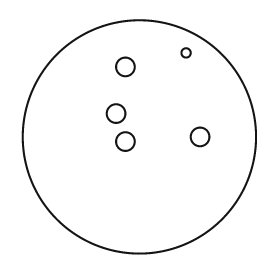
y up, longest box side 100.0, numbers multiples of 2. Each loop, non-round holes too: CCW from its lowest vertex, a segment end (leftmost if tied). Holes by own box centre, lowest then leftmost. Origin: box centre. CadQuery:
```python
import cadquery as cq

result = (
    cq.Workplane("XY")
    .moveTo(0.0, 0.0)
    .circle(50.0)
    .moveTo(-6.0, -2.0)
    .circle(4.0)
    .moveTo(26.0, 0.0)
    .circle(4.0)
    .moveTo(-10.0, 10.0)
    .circle(4.0)
    .moveTo(-6.0, 30.0)
    .circle(4.0)
    .moveTo(20.0, 36.0)
    .circle(2.0)
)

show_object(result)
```